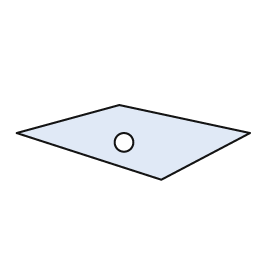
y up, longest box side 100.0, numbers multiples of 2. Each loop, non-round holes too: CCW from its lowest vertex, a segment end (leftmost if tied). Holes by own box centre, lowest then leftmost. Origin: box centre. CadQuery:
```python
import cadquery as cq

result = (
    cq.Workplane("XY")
    .moveTo(12.0, -16.0)
    .lineTo(50.0, 4.0)
    .lineTo(-6.0, 16.0)
    .lineTo(-50.0, 4.0)
    .close()
    .moveTo(-4.0, 0.0)
    .circle(4.0)
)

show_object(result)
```